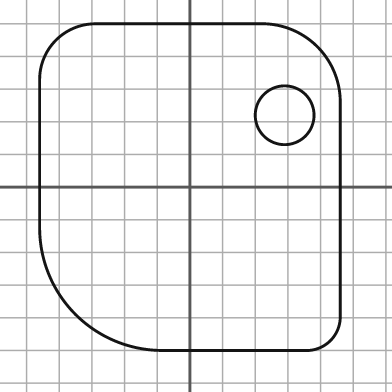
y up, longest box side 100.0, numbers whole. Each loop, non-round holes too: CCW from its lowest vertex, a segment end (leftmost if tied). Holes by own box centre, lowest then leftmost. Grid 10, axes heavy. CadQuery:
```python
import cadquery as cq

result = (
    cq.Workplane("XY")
    .moveTo(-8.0, -50.0)
    .lineTo(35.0, -50.0)
    .threePointArc((43.0, -47.0), (46.0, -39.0))
    .lineTo(46.0, 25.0)
    .threePointArc((39.0, 43.0), (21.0, 50.0))
    .lineTo(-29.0, 50.0)
    .threePointArc((-41.0, 45.0), (-46.0, 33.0))
    .lineTo(-46.0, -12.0)
    .threePointArc((-35.0, -39.0), (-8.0, -50.0))
    .close()
    .moveTo(29.0, 22.0)
    .circle(9.0)
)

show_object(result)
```